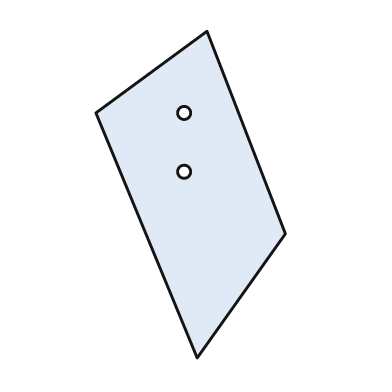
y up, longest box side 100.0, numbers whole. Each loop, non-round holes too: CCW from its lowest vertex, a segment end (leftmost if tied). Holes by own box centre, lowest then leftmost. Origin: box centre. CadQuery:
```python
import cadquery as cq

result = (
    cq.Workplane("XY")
    .moveTo(2.0, -50.0)
    .lineTo(29.0, -12.0)
    .lineTo(5.0, 50.0)
    .lineTo(-29.0, 25.0)
    .close()
    .moveTo(-2.0, 7.0)
    .circle(2.0)
    .moveTo(-2.0, 25.0)
    .circle(2.0)
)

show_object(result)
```